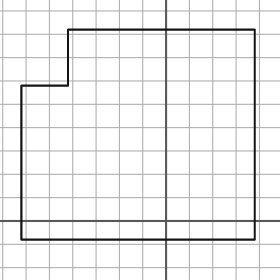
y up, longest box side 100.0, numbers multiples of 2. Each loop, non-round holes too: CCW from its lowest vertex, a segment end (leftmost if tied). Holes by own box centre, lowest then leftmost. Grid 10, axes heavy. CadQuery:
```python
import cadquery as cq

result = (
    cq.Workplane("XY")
    .moveTo(-62.0, -8.0)
    .lineTo(38.0, -8.0)
    .lineTo(38.0, 82.0)
    .lineTo(-42.0, 82.0)
    .lineTo(-42.0, 58.0)
    .lineTo(-62.0, 58.0)
    .close()
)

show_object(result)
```